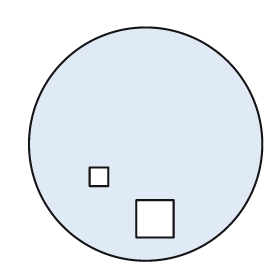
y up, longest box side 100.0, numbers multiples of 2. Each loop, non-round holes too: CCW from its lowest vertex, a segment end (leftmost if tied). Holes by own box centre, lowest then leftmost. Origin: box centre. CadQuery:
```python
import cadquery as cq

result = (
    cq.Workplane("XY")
    .moveTo(0.0, 0.0)
    .circle(50.0)
    .moveTo(-4.0, -40.0)
    .lineTo(12.0, -40.0)
    .lineTo(12.0, -24.0)
    .lineTo(-4.0, -24.0)
    .close()
    .moveTo(-24.0, -18.0)
    .lineTo(-16.0, -18.0)
    .lineTo(-16.0, -10.0)
    .lineTo(-24.0, -10.0)
    .close()
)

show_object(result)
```